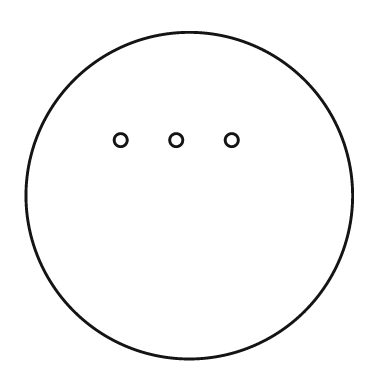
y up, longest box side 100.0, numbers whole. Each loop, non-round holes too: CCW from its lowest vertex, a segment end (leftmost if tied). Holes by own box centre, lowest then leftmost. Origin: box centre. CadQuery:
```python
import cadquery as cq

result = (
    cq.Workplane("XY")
    .moveTo(0.0, 0.0)
    .circle(50.0)
    .moveTo(-21.0, 17.0)
    .circle(2.0)
    .moveTo(-4.0, 17.0)
    .circle(2.0)
    .moveTo(13.0, 17.0)
    .circle(2.0)
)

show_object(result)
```